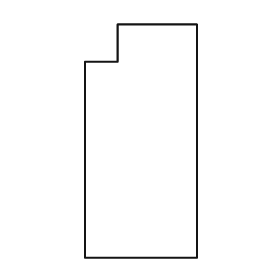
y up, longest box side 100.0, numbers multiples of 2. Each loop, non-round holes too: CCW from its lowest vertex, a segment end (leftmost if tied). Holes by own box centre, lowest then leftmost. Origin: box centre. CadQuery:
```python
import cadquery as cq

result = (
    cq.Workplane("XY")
    .moveTo(-24.0, -50.0)
    .lineTo(24.0, -50.0)
    .lineTo(24.0, 50.0)
    .lineTo(-10.0, 50.0)
    .lineTo(-10.0, 34.0)
    .lineTo(-24.0, 34.0)
    .close()
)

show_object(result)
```